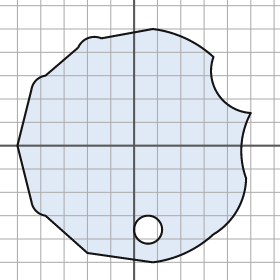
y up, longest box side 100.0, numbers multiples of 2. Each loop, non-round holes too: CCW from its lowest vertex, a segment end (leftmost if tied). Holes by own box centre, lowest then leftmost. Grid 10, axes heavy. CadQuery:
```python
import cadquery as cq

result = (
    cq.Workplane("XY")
    .moveTo(8.0, -50.0)
    .threePointArc((22.0, -46.0), (34.0, -38.0))
    .threePointArc((44.0, -28.0), (48.0, -14.0))
    .threePointArc((46.0, 0.0), (50.0, 14.0))
    .threePointArc((36.0, 22.0), (34.0, 38.0))
    .threePointArc((22.0, 46.0), (8.0, 50.0))
    .lineTo(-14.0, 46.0)
    .threePointArc((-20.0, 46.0), (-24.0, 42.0))
    .lineTo(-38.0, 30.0)
    .threePointArc((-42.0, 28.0), (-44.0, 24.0))
    .lineTo(-50.0, 0.0)
    .lineTo(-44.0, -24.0)
    .threePointArc((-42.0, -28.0), (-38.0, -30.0))
    .lineTo(-20.0, -46.0)
    .close()
    .moveTo(6.0, -36.0)
    .circle(6.0)
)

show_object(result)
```